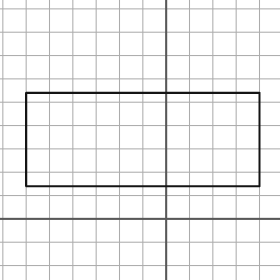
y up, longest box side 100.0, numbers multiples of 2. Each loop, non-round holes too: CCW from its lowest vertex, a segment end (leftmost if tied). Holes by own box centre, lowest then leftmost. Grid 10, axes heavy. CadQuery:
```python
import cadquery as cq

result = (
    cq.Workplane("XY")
    .moveTo(-60.0, 14.0)
    .lineTo(40.0, 14.0)
    .lineTo(40.0, 54.0)
    .lineTo(-60.0, 54.0)
    .close()
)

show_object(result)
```